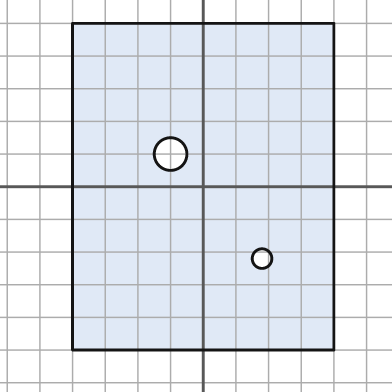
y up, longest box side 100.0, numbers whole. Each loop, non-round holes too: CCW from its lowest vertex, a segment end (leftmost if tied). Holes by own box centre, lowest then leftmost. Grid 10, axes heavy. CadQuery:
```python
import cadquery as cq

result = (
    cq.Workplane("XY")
    .moveTo(-40.0, -50.0)
    .lineTo(40.0, -50.0)
    .lineTo(40.0, 50.0)
    .lineTo(-40.0, 50.0)
    .close()
    .moveTo(18.0, -22.0)
    .circle(3.0)
    .moveTo(-10.0, 10.0)
    .circle(5.0)
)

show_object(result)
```